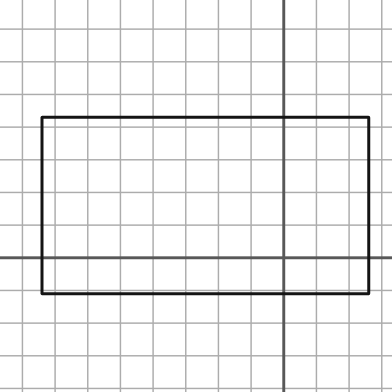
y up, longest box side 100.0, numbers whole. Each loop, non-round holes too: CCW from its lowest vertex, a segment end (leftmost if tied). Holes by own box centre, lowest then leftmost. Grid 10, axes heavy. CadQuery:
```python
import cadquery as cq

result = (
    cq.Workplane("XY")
    .moveTo(-74.0, -11.0)
    .lineTo(26.0, -11.0)
    .lineTo(26.0, 43.0)
    .lineTo(-74.0, 43.0)
    .close()
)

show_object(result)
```